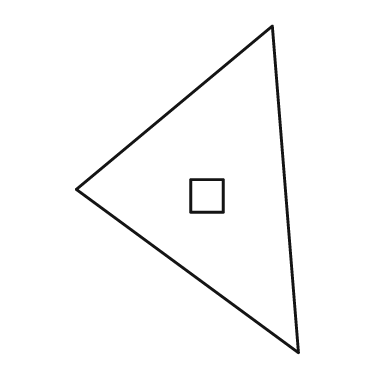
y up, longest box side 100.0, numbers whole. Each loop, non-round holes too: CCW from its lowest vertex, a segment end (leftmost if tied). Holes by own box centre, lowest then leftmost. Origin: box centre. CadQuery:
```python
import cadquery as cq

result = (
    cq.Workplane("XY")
    .moveTo(34.0, -50.0)
    .lineTo(26.0, 50.0)
    .lineTo(-34.0, 0.0)
    .close()
    .moveTo(1.0, -7.0)
    .lineTo(11.0, -7.0)
    .lineTo(11.0, 3.0)
    .lineTo(1.0, 3.0)
    .close()
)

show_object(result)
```